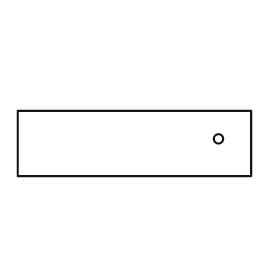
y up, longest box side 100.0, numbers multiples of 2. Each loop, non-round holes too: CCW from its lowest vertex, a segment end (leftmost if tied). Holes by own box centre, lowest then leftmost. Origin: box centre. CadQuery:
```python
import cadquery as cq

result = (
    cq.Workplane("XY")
    .moveTo(-50.0, -14.0)
    .lineTo(50.0, -14.0)
    .lineTo(50.0, 14.0)
    .lineTo(-50.0, 14.0)
    .close()
    .moveTo(36.0, 2.0)
    .circle(2.0)
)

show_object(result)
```